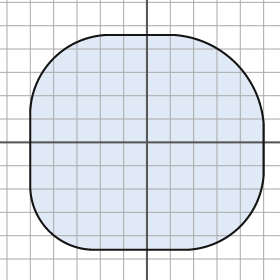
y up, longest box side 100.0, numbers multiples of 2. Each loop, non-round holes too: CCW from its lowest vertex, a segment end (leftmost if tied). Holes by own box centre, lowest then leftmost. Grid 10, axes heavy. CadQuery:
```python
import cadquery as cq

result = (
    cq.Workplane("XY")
    .moveTo(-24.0, -46.0)
    .lineTo(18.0, -46.0)
    .threePointArc((40.0, -36.0), (50.0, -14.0))
    .lineTo(50.0, 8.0)
    .threePointArc((38.0, 34.0), (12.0, 46.0))
    .lineTo(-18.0, 46.0)
    .threePointArc((-40.0, 36.0), (-50.0, 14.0))
    .lineTo(-50.0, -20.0)
    .threePointArc((-42.0, -38.0), (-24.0, -46.0))
    .close()
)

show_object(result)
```